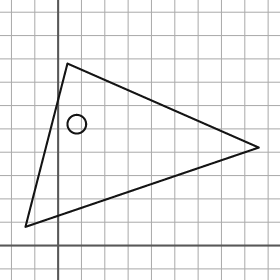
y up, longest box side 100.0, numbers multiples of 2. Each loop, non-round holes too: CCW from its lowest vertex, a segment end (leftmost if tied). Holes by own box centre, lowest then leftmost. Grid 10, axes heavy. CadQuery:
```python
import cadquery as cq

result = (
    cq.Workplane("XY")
    .moveTo(-14.0, 8.0)
    .lineTo(86.0, 42.0)
    .lineTo(4.0, 78.0)
    .close()
    .moveTo(8.0, 52.0)
    .circle(4.0)
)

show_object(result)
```